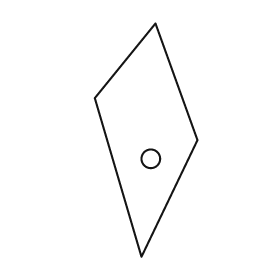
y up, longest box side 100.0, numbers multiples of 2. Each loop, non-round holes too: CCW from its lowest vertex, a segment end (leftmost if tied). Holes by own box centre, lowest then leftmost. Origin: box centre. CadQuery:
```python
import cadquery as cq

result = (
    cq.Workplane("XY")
    .moveTo(-2.0, -50.0)
    .lineTo(22.0, 0.0)
    .lineTo(4.0, 50.0)
    .lineTo(-22.0, 18.0)
    .close()
    .moveTo(2.0, -8.0)
    .circle(4.0)
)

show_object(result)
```